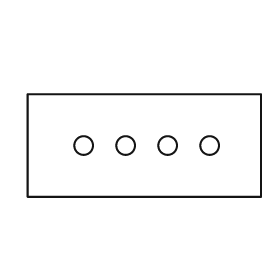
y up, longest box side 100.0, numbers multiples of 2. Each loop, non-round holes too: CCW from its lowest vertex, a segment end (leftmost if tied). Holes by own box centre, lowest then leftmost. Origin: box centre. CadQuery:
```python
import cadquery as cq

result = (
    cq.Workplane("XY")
    .moveTo(-50.0, -22.0)
    .lineTo(50.0, -22.0)
    .lineTo(50.0, 22.0)
    .lineTo(-50.0, 22.0)
    .close()
    .moveTo(-26.0, 0.0)
    .circle(4.0)
    .moveTo(-8.0, 0.0)
    .circle(4.0)
    .moveTo(10.0, 0.0)
    .circle(4.0)
    .moveTo(28.0, 0.0)
    .circle(4.0)
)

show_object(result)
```